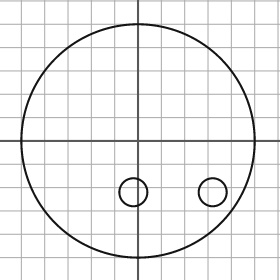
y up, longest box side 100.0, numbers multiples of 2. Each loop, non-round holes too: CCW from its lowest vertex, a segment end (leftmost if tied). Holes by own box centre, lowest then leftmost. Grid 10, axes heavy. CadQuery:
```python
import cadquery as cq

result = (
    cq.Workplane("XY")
    .moveTo(0.0, 0.0)
    .circle(50.0)
    .moveTo(-2.0, -22.0)
    .circle(6.0)
    .moveTo(32.0, -22.0)
    .circle(6.0)
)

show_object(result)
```